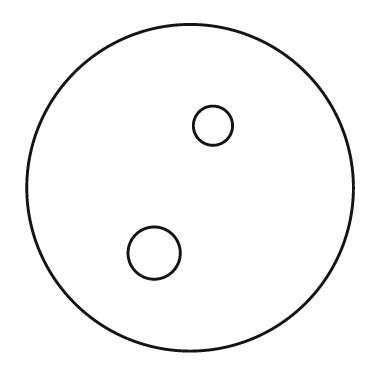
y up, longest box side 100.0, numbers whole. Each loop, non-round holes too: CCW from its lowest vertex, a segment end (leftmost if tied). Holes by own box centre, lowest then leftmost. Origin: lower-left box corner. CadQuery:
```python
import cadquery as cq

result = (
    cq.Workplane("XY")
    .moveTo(50.0, 50.0)
    .circle(50.0)
    .moveTo(39.0, 30.0)
    .circle(8.0)
    .moveTo(57.0, 69.0)
    .circle(6.0)
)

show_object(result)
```